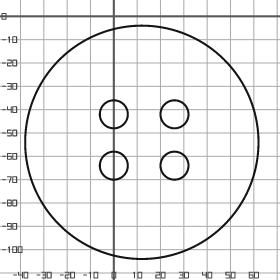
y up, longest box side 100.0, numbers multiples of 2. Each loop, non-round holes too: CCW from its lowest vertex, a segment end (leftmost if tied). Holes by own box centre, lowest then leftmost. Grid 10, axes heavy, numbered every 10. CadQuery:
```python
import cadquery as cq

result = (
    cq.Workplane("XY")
    .moveTo(12.0, -54.0)
    .circle(50.0)
    .moveTo(0.0, -64.0)
    .circle(6.0)
    .moveTo(26.0, -64.0)
    .circle(6.0)
    .moveTo(0.0, -42.0)
    .circle(6.0)
    .moveTo(26.0, -42.0)
    .circle(6.0)
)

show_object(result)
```